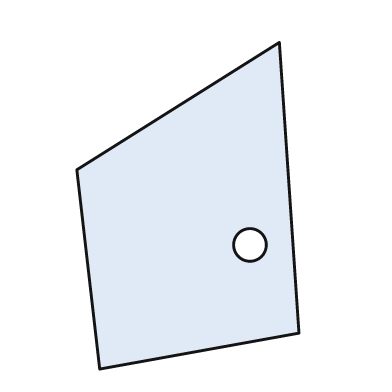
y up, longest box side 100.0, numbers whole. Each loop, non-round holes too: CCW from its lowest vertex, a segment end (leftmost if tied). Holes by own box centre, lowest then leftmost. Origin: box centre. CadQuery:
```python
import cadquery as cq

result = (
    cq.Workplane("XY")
    .moveTo(-27.0, -50.0)
    .lineTo(34.0, -39.0)
    .lineTo(28.0, 50.0)
    .lineTo(-34.0, 11.0)
    .close()
    .moveTo(19.0, -12.0)
    .circle(5.0)
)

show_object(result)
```